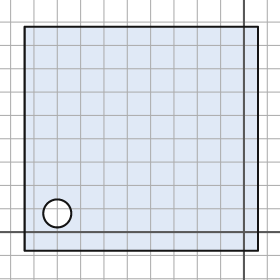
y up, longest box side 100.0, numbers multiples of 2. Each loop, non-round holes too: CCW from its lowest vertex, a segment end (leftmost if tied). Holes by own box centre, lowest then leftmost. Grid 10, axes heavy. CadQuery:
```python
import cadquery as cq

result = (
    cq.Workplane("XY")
    .moveTo(-94.0, -8.0)
    .lineTo(6.0, -8.0)
    .lineTo(6.0, 88.0)
    .lineTo(-94.0, 88.0)
    .close()
    .moveTo(-80.0, 8.0)
    .circle(6.0)
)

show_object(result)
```